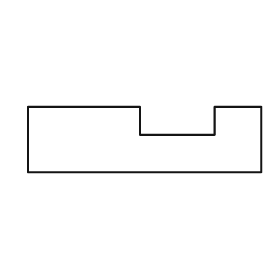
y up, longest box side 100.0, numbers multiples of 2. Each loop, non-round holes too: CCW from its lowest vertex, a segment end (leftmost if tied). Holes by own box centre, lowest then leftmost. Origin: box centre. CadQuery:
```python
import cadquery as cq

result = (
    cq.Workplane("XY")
    .moveTo(-50.0, -14.0)
    .lineTo(50.0, -14.0)
    .lineTo(50.0, 14.0)
    .lineTo(30.0, 14.0)
    .lineTo(30.0, 2.0)
    .lineTo(-2.0, 2.0)
    .lineTo(-2.0, 14.0)
    .lineTo(-50.0, 14.0)
    .close()
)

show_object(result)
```